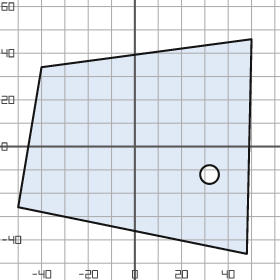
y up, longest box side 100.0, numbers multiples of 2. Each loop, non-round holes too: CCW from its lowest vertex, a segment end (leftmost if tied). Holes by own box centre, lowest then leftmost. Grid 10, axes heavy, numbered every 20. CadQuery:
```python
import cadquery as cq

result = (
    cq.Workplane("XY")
    .moveTo(48.0, -46.0)
    .lineTo(50.0, 46.0)
    .lineTo(-40.0, 34.0)
    .lineTo(-50.0, -26.0)
    .close()
    .moveTo(32.0, -12.0)
    .circle(4.0)
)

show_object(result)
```